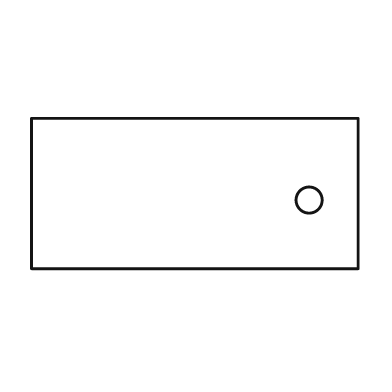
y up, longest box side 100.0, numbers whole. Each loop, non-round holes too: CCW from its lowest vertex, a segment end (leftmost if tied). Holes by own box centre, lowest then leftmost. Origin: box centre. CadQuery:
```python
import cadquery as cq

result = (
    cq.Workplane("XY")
    .moveTo(-50.0, -23.0)
    .lineTo(50.0, -23.0)
    .lineTo(50.0, 23.0)
    .lineTo(-50.0, 23.0)
    .close()
    .moveTo(35.0, -2.0)
    .circle(4.0)
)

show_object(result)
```